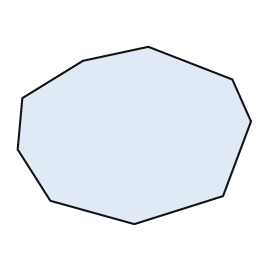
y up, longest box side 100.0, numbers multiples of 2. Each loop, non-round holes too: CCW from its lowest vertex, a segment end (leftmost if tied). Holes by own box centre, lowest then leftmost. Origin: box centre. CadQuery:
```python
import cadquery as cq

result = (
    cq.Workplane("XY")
    .moveTo(0.0, -38.0)
    .lineTo(38.0, -26.0)
    .lineTo(50.0, 6.0)
    .lineTo(42.0, 24.0)
    .lineTo(6.0, 38.0)
    .lineTo(-22.0, 32.0)
    .lineTo(-48.0, 16.0)
    .lineTo(-50.0, -6.0)
    .lineTo(-36.0, -28.0)
    .close()
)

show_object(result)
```